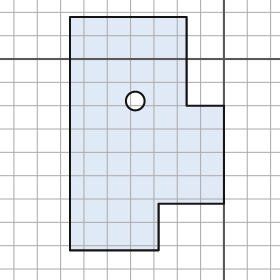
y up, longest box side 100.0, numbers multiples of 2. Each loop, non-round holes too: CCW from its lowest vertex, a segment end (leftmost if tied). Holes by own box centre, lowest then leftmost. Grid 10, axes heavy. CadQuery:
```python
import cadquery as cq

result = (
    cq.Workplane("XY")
    .moveTo(-66.0, -82.0)
    .lineTo(-28.0, -82.0)
    .lineTo(-28.0, -62.0)
    .lineTo(0.0, -62.0)
    .lineTo(0.0, -20.0)
    .lineTo(-16.0, -20.0)
    .lineTo(-16.0, 18.0)
    .lineTo(-66.0, 18.0)
    .close()
    .moveTo(-38.0, -18.0)
    .circle(4.0)
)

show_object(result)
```